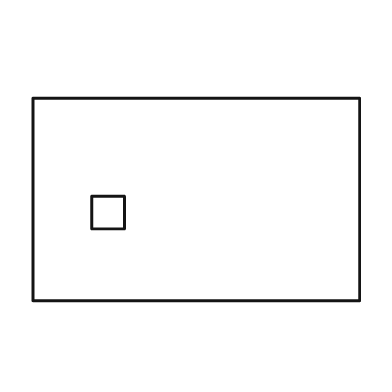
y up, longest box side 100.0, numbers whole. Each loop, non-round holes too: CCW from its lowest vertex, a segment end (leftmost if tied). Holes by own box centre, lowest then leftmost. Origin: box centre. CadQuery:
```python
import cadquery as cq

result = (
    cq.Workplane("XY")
    .moveTo(-50.0, -31.0)
    .lineTo(50.0, -31.0)
    .lineTo(50.0, 31.0)
    .lineTo(-50.0, 31.0)
    .close()
    .moveTo(-32.0, -9.0)
    .lineTo(-22.0, -9.0)
    .lineTo(-22.0, 1.0)
    .lineTo(-32.0, 1.0)
    .close()
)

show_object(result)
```